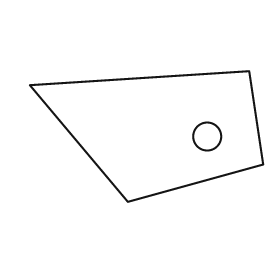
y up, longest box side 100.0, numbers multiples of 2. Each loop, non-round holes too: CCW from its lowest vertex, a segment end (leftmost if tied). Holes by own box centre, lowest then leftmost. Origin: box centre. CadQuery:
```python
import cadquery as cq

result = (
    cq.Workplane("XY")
    .moveTo(-8.0, -28.0)
    .lineTo(50.0, -12.0)
    .lineTo(44.0, 28.0)
    .lineTo(-50.0, 22.0)
    .close()
    .moveTo(26.0, 0.0)
    .circle(6.0)
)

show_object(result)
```